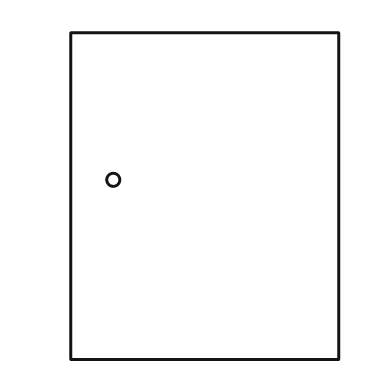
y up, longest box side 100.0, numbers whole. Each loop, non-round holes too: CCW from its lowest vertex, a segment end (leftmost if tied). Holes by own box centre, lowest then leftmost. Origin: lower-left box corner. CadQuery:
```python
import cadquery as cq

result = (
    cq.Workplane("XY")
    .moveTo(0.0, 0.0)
    .lineTo(82.0, 0.0)
    .lineTo(82.0, 100.0)
    .lineTo(0.0, 100.0)
    .close()
    .moveTo(13.0, 55.0)
    .circle(2.0)
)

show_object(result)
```